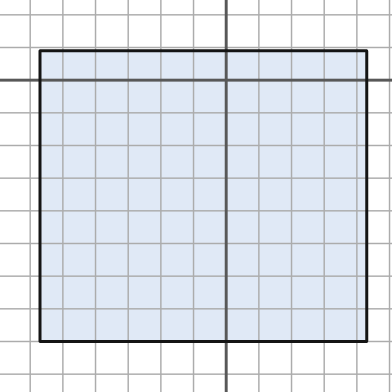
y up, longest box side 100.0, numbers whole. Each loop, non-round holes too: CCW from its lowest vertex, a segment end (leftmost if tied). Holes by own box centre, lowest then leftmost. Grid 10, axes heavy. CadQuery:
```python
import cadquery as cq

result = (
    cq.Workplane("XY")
    .moveTo(-57.0, -80.0)
    .lineTo(43.0, -80.0)
    .lineTo(43.0, 9.0)
    .lineTo(-57.0, 9.0)
    .close()
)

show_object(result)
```